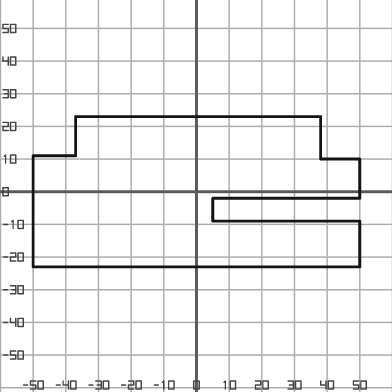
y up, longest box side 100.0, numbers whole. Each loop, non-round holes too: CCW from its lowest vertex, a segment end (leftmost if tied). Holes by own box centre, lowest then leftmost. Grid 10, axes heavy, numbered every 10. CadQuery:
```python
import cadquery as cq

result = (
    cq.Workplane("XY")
    .moveTo(-50.0, -23.0)
    .lineTo(50.0, -23.0)
    .lineTo(50.0, -9.0)
    .lineTo(5.0, -9.0)
    .lineTo(5.0, -2.0)
    .lineTo(50.0, -2.0)
    .lineTo(50.0, 10.0)
    .lineTo(38.0, 10.0)
    .lineTo(38.0, 23.0)
    .lineTo(-37.0, 23.0)
    .lineTo(-37.0, 11.0)
    .lineTo(-50.0, 11.0)
    .close()
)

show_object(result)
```